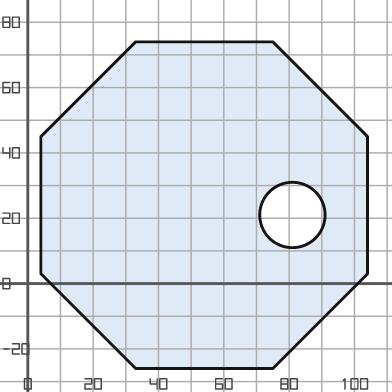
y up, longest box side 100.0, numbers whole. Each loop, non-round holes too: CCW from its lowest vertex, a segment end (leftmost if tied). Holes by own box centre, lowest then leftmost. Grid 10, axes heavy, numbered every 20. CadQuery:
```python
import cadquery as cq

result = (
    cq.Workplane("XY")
    .moveTo(33.0, -26.0)
    .lineTo(75.0, -26.0)
    .lineTo(104.0, 3.0)
    .lineTo(104.0, 45.0)
    .lineTo(75.0, 74.0)
    .lineTo(33.0, 74.0)
    .lineTo(4.0, 45.0)
    .lineTo(4.0, 3.0)
    .close()
    .moveTo(81.0, 21.0)
    .circle(10.0)
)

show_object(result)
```